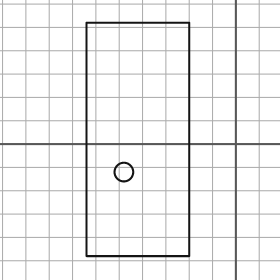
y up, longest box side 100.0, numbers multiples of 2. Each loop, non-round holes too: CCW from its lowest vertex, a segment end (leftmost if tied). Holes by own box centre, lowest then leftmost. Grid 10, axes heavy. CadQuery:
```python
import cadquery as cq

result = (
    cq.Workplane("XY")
    .moveTo(-64.0, -48.0)
    .lineTo(-20.0, -48.0)
    .lineTo(-20.0, 52.0)
    .lineTo(-64.0, 52.0)
    .close()
    .moveTo(-48.0, -12.0)
    .circle(4.0)
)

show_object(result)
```